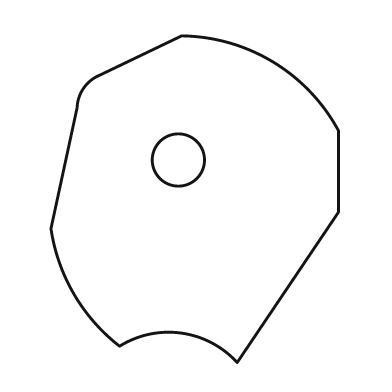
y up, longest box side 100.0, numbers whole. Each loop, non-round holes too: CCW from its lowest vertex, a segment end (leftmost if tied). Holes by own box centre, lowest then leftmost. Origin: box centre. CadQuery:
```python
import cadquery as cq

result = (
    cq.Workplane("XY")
    .moveTo(13.0, -50.0)
    .lineTo(44.0, -4.0)
    .lineTo(44.0, 21.0)
    .threePointArc((24.0, 42.0), (-4.0, 50.0))
    .lineTo(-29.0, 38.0)
    .threePointArc((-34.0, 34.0), (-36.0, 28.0))
    .lineTo(-44.0, -9.0)
    .threePointArc((-37.0, -29.0), (-23.0, -45.0))
    .threePointArc((-4.0, -41.0), (13.0, -50.0))
    .close()
    .moveTo(-5.0, 12.0)
    .circle(8.0)
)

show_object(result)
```